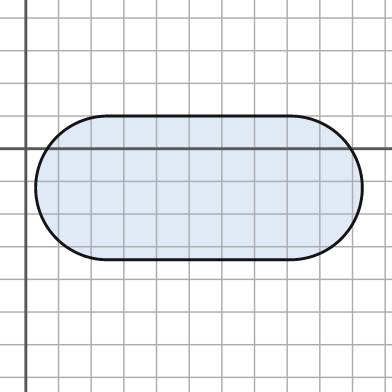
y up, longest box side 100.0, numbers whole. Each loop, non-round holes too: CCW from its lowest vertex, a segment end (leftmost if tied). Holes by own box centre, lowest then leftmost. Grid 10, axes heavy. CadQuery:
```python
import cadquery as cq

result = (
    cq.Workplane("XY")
    .moveTo(25.0, -34.0)
    .lineTo(81.0, -34.0)
    .threePointArc((103.0, -12.0), (81.0, 10.0))
    .lineTo(25.0, 10.0)
    .threePointArc((3.0, -12.0), (25.0, -34.0))
    .close()
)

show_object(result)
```